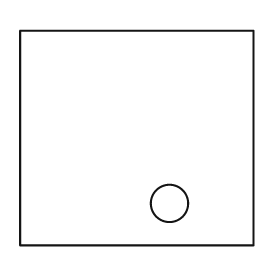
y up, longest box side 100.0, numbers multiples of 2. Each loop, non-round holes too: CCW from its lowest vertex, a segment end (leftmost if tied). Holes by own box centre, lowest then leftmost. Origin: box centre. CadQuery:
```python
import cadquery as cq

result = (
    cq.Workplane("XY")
    .moveTo(-50.0, -46.0)
    .lineTo(50.0, -46.0)
    .lineTo(50.0, 46.0)
    .lineTo(-50.0, 46.0)
    .close()
    .moveTo(14.0, -28.0)
    .circle(8.0)
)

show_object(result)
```